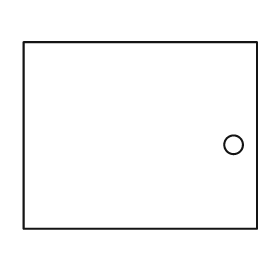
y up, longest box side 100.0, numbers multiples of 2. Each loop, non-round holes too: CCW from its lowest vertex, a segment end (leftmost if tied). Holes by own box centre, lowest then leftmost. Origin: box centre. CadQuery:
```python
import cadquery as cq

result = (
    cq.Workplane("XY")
    .moveTo(-50.0, -40.0)
    .lineTo(50.0, -40.0)
    .lineTo(50.0, 40.0)
    .lineTo(-50.0, 40.0)
    .close()
    .moveTo(40.0, -4.0)
    .circle(4.0)
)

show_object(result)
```